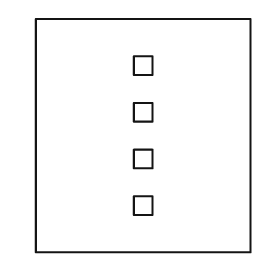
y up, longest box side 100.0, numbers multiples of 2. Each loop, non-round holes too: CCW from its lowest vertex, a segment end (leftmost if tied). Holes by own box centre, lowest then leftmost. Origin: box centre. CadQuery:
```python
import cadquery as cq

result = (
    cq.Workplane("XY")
    .moveTo(-46.0, -50.0)
    .lineTo(46.0, -50.0)
    .lineTo(46.0, 50.0)
    .lineTo(-46.0, 50.0)
    .close()
    .moveTo(-4.0, -34.0)
    .lineTo(4.0, -34.0)
    .lineTo(4.0, -26.0)
    .lineTo(-4.0, -26.0)
    .close()
    .moveTo(-4.0, -14.0)
    .lineTo(4.0, -14.0)
    .lineTo(4.0, -6.0)
    .lineTo(-4.0, -6.0)
    .close()
    .moveTo(-4.0, 6.0)
    .lineTo(4.0, 6.0)
    .lineTo(4.0, 14.0)
    .lineTo(-4.0, 14.0)
    .close()
    .moveTo(-4.0, 26.0)
    .lineTo(4.0, 26.0)
    .lineTo(4.0, 34.0)
    .lineTo(-4.0, 34.0)
    .close()
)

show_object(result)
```